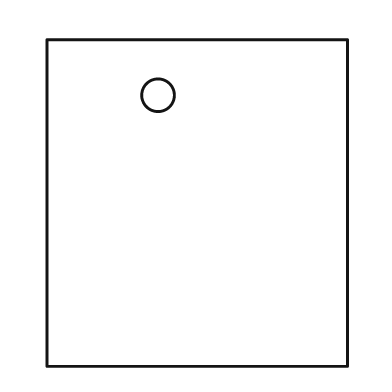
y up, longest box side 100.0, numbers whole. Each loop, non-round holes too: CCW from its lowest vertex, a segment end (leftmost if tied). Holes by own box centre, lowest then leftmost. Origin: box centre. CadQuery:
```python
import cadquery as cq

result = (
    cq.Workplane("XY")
    .moveTo(-46.0, -50.0)
    .lineTo(46.0, -50.0)
    .lineTo(46.0, 50.0)
    .lineTo(-46.0, 50.0)
    .close()
    .moveTo(-12.0, 33.0)
    .circle(5.0)
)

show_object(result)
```